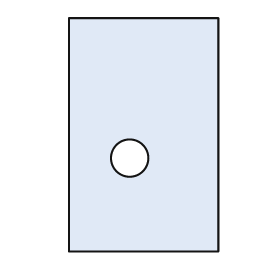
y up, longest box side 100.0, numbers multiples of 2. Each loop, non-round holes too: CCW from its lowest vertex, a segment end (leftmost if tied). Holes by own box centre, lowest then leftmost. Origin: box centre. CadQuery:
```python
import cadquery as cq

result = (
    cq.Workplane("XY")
    .moveTo(-32.0, -50.0)
    .lineTo(32.0, -50.0)
    .lineTo(32.0, 50.0)
    .lineTo(-32.0, 50.0)
    .close()
    .moveTo(-6.0, -10.0)
    .circle(8.0)
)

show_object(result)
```